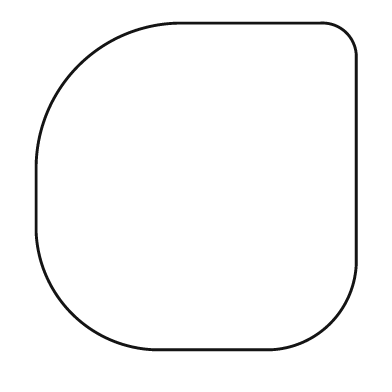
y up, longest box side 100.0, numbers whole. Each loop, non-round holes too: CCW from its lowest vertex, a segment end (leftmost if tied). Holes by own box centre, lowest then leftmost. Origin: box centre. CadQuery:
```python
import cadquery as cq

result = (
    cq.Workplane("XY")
    .moveTo(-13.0, -50.0)
    .lineTo(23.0, -50.0)
    .threePointArc((41.0, -42.0), (49.0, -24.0))
    .lineTo(49.0, 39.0)
    .threePointArc((46.0, 47.0), (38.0, 50.0))
    .lineTo(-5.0, 50.0)
    .threePointArc((-36.0, 37.0), (-49.0, 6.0))
    .lineTo(-49.0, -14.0)
    .threePointArc((-38.0, -39.0), (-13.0, -50.0))
    .close()
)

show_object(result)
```